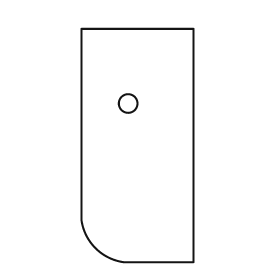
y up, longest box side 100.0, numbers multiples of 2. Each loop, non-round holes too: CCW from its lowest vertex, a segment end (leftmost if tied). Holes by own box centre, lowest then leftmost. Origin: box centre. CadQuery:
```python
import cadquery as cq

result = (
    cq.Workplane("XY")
    .moveTo(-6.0, -50.0)
    .lineTo(24.0, -50.0)
    .lineTo(24.0, 50.0)
    .lineTo(-24.0, 50.0)
    .lineTo(-24.0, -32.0)
    .threePointArc((-18.0, -44.0), (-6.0, -50.0))
    .close()
    .moveTo(-4.0, 18.0)
    .circle(4.0)
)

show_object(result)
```